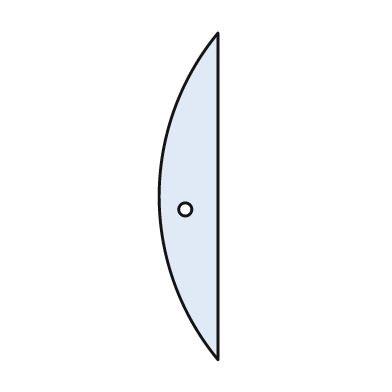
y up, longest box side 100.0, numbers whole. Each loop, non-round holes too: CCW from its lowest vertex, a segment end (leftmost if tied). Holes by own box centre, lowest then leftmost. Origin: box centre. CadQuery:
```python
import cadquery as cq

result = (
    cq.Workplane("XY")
    .moveTo(9.0, -50.0)
    .lineTo(9.0, 50.0)
    .threePointArc((-9.0, 0.0), (9.0, -50.0))
    .close()
    .moveTo(-1.0, -4.0)
    .circle(2.0)
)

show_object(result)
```